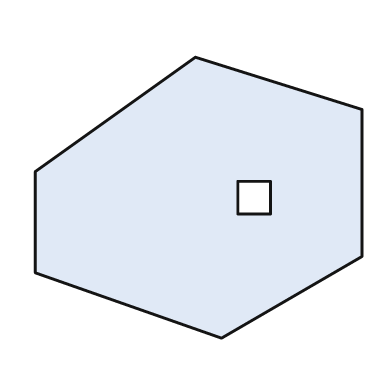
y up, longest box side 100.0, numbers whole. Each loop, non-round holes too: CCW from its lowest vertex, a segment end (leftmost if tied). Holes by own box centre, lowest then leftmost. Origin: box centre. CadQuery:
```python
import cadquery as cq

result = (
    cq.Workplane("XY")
    .moveTo(7.0, -43.0)
    .lineTo(50.0, -18.0)
    .lineTo(50.0, 27.0)
    .lineTo(-1.0, 43.0)
    .lineTo(-50.0, 8.0)
    .lineTo(-50.0, -23.0)
    .close()
    .moveTo(12.0, -5.0)
    .lineTo(22.0, -5.0)
    .lineTo(22.0, 5.0)
    .lineTo(12.0, 5.0)
    .close()
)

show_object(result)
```